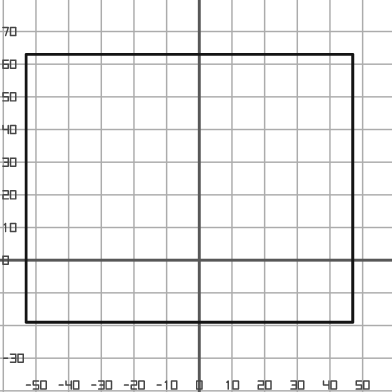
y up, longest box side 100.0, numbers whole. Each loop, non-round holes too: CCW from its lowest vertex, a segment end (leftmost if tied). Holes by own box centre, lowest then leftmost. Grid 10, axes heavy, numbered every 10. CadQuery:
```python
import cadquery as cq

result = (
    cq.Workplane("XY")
    .moveTo(-53.0, -19.0)
    .lineTo(47.0, -19.0)
    .lineTo(47.0, 63.0)
    .lineTo(-53.0, 63.0)
    .close()
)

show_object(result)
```